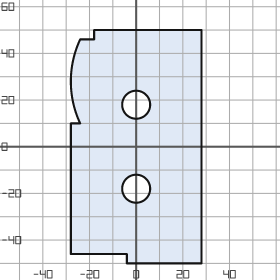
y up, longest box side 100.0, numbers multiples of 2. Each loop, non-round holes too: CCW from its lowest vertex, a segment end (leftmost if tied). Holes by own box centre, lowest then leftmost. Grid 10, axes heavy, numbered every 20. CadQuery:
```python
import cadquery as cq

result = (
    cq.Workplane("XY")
    .moveTo(-4.0, -50.0)
    .lineTo(28.0, -50.0)
    .lineTo(28.0, 50.0)
    .lineTo(-18.0, 50.0)
    .lineTo(-18.0, 46.0)
    .lineTo(-24.0, 46.0)
    .threePointArc((-28.0, 28.0), (-24.0, 10.0))
    .lineTo(-28.0, 10.0)
    .lineTo(-28.0, -46.0)
    .lineTo(-4.0, -46.0)
    .close()
    .moveTo(0.0, -18.0)
    .circle(6.0)
    .moveTo(0.0, 18.0)
    .circle(6.0)
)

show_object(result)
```